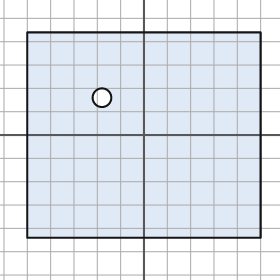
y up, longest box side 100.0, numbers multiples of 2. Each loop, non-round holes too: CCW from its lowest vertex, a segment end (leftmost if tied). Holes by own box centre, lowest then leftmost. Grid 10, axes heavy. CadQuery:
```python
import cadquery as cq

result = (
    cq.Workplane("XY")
    .moveTo(-50.0, -44.0)
    .lineTo(50.0, -44.0)
    .lineTo(50.0, 44.0)
    .lineTo(-50.0, 44.0)
    .close()
    .moveTo(-18.0, 16.0)
    .circle(4.0)
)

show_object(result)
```